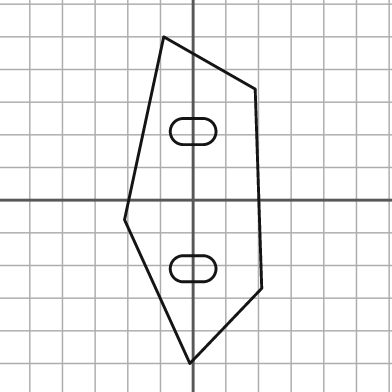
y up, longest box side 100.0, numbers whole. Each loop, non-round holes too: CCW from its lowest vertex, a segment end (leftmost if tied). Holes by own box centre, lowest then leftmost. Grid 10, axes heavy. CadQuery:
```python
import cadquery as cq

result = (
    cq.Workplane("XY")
    .moveTo(-1.0, -50.0)
    .lineTo(21.0, -27.0)
    .lineTo(19.0, 34.0)
    .lineTo(-9.0, 50.0)
    .lineTo(-21.0, -6.0)
    .close()
    .moveTo(-3.0, -25.0)
    .lineTo(3.0, -25.0)
    .threePointArc((7.0, -21.0), (3.0, -17.0))
    .lineTo(-3.0, -17.0)
    .threePointArc((-7.0, -21.0), (-3.0, -25.0))
    .close()
    .moveTo(-3.0, 17.0)
    .lineTo(3.0, 17.0)
    .threePointArc((7.0, 21.0), (3.0, 25.0))
    .lineTo(-3.0, 25.0)
    .threePointArc((-7.0, 21.0), (-3.0, 17.0))
    .close()
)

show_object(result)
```